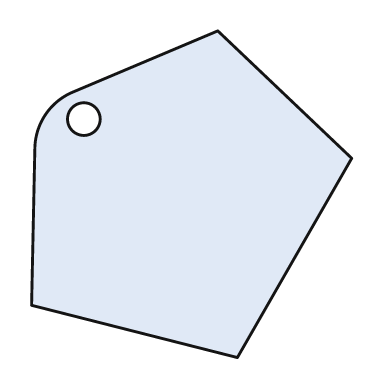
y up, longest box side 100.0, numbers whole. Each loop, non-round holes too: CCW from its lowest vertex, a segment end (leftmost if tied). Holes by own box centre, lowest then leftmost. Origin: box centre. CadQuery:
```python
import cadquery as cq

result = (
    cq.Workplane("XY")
    .moveTo(14.0, -50.0)
    .lineTo(49.0, 11.0)
    .lineTo(8.0, 50.0)
    .lineTo(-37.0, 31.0)
    .threePointArc((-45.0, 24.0), (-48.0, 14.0))
    .lineTo(-49.0, -34.0)
    .close()
    .moveTo(-33.0, 23.0)
    .circle(5.0)
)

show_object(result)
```